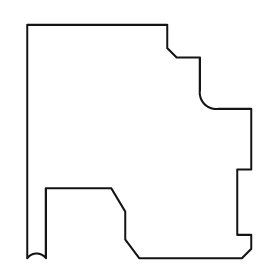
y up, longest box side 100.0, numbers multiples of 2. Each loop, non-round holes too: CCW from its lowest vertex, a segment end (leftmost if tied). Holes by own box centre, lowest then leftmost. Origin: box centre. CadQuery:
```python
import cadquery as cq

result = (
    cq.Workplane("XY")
    .moveTo(-48.0, -50.0)
    .threePointArc((-44.0, -48.0), (-40.0, -50.0))
    .lineTo(-40.0, -20.0)
    .lineTo(-12.0, -20.0)
    .lineTo(-6.0, -30.0)
    .lineTo(-6.0, -42.0)
    .lineTo(0.0, -50.0)
    .lineTo(44.0, -50.0)
    .lineTo(48.0, -46.0)
    .lineTo(48.0, -40.0)
    .lineTo(42.0, -40.0)
    .lineTo(42.0, -12.0)
    .lineTo(48.0, -12.0)
    .lineTo(48.0, 14.0)
    .lineTo(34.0, 14.0)
    .threePointArc((28.0, 16.0), (26.0, 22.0))
    .lineTo(26.0, 36.0)
    .lineTo(16.0, 36.0)
    .lineTo(12.0, 40.0)
    .lineTo(12.0, 50.0)
    .lineTo(-48.0, 50.0)
    .close()
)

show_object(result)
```